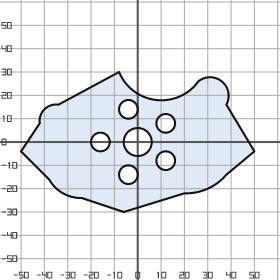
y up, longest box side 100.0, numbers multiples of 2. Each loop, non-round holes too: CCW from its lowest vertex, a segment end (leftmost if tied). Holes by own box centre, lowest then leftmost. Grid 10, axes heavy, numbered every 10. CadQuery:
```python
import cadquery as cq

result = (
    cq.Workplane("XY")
    .moveTo(-6.0, -30.0)
    .lineTo(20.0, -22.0)
    .threePointArc((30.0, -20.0), (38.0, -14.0))
    .lineTo(50.0, -4.0)
    .lineTo(38.0, 16.0)
    .threePointArc((36.0, 26.0), (26.0, 26.0))
    .threePointArc((8.0, 18.0), (-8.0, 30.0))
    .lineTo(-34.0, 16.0)
    .threePointArc((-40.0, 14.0), (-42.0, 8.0))
    .lineTo(-50.0, -4.0)
    .lineTo(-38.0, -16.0)
    .threePointArc((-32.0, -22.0), (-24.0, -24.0))
    .close()
    .moveTo(-4.0, -14.0)
    .circle(4.0)
    .moveTo(12.0, -8.0)
    .circle(4.0)
    .moveTo(-16.0, 0.0)
    .circle(4.0)
    .moveTo(0.0, 0.0)
    .circle(6.0)
    .moveTo(12.0, 8.0)
    .circle(4.0)
    .moveTo(-4.0, 14.0)
    .circle(4.0)
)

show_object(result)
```